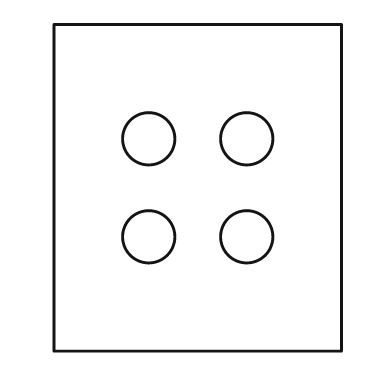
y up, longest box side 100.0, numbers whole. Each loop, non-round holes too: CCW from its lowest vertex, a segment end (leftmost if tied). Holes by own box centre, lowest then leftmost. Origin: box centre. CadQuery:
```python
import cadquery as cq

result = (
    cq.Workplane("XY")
    .moveTo(-44.0, -50.0)
    .lineTo(44.0, -50.0)
    .lineTo(44.0, 50.0)
    .lineTo(-44.0, 50.0)
    .close()
    .moveTo(-15.0, -15.0)
    .circle(8.0)
    .moveTo(15.0, -15.0)
    .circle(8.0)
    .moveTo(-15.0, 15.0)
    .circle(8.0)
    .moveTo(15.0, 15.0)
    .circle(8.0)
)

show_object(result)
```